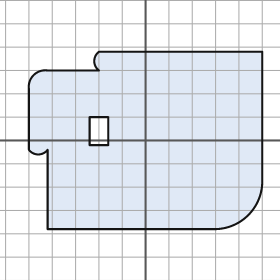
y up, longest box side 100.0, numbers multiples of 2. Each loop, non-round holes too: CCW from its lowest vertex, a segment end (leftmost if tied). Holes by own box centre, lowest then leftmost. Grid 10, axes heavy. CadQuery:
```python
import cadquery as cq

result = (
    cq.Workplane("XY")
    .moveTo(-42.0, -38.0)
    .lineTo(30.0, -38.0)
    .threePointArc((44.0, -32.0), (50.0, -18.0))
    .lineTo(50.0, 38.0)
    .lineTo(-20.0, 38.0)
    .threePointArc((-22.0, 34.0), (-20.0, 30.0))
    .lineTo(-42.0, 30.0)
    .threePointArc((-48.0, 28.0), (-50.0, 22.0))
    .lineTo(-50.0, -4.0)
    .threePointArc((-46.0, -6.0), (-42.0, -4.0))
    .close()
    .moveTo(-24.0, -2.0)
    .lineTo(-16.0, -2.0)
    .lineTo(-16.0, 10.0)
    .lineTo(-24.0, 10.0)
    .close()
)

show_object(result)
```